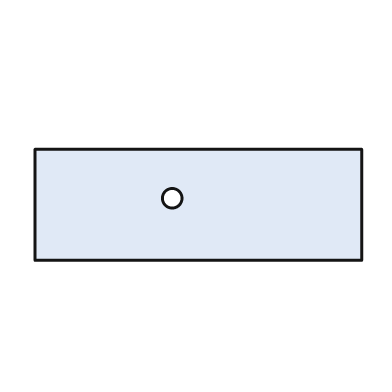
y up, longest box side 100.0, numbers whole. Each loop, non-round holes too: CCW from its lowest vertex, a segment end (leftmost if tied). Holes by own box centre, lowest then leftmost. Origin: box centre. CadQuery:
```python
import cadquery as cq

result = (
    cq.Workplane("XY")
    .moveTo(-50.0, -17.0)
    .lineTo(50.0, -17.0)
    .lineTo(50.0, 17.0)
    .lineTo(-50.0, 17.0)
    .close()
    .moveTo(-8.0, 2.0)
    .circle(3.0)
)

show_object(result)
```